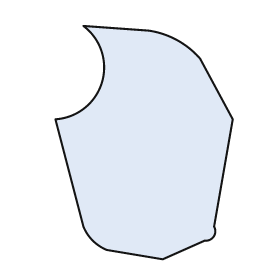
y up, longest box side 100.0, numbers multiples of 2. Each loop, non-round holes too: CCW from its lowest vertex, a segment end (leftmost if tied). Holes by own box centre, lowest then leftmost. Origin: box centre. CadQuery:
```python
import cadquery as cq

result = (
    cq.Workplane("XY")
    .moveTo(8.0, -50.0)
    .lineTo(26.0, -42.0)
    .threePointArc((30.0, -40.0), (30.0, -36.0))
    .lineTo(38.0, 10.0)
    .lineTo(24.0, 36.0)
    .threePointArc((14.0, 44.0), (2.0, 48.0))
    .lineTo(-26.0, 50.0)
    .threePointArc((-18.0, 26.0), (-38.0, 10.0))
    .lineTo(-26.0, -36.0)
    .threePointArc((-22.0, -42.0), (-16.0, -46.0))
    .close()
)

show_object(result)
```